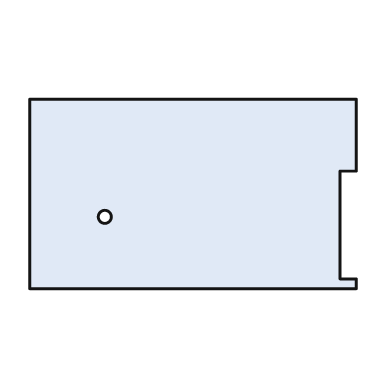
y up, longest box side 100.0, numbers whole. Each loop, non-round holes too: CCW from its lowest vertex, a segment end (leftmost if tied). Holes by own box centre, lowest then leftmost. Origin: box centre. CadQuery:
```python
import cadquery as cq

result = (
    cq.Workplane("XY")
    .moveTo(-50.0, -29.0)
    .lineTo(50.0, -29.0)
    .lineTo(50.0, -26.0)
    .lineTo(45.0, -26.0)
    .lineTo(45.0, 7.0)
    .lineTo(50.0, 7.0)
    .lineTo(50.0, 29.0)
    .lineTo(-50.0, 29.0)
    .close()
    .moveTo(-27.0, -7.0)
    .circle(2.0)
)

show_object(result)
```